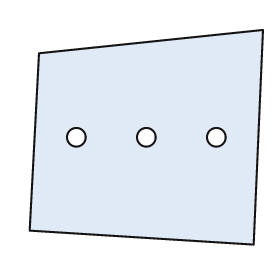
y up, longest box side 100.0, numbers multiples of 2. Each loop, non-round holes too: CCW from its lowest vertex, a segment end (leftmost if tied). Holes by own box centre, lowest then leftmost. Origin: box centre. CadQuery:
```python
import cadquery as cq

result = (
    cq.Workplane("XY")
    .moveTo(46.0, -46.0)
    .lineTo(50.0, 46.0)
    .lineTo(-46.0, 36.0)
    .lineTo(-50.0, -40.0)
    .close()
    .moveTo(-30.0, 0.0)
    .circle(4.0)
    .moveTo(0.0, 0.0)
    .circle(4.0)
    .moveTo(30.0, 0.0)
    .circle(4.0)
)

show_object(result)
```